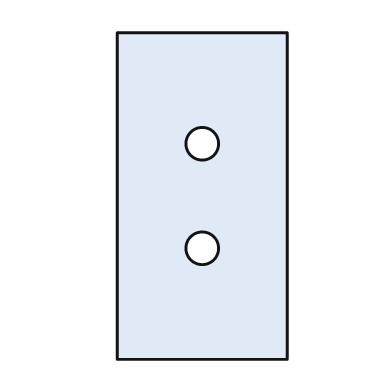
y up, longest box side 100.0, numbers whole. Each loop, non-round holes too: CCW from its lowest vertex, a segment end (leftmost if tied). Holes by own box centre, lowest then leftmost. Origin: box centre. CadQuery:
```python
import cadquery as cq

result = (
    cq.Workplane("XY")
    .moveTo(-26.0, -50.0)
    .lineTo(26.0, -50.0)
    .lineTo(26.0, 50.0)
    .lineTo(-26.0, 50.0)
    .close()
    .moveTo(0.0, -16.0)
    .circle(5.0)
    .moveTo(0.0, 16.0)
    .circle(5.0)
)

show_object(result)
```